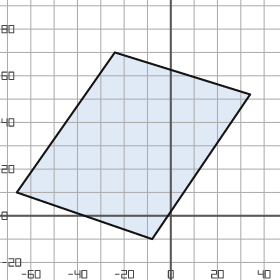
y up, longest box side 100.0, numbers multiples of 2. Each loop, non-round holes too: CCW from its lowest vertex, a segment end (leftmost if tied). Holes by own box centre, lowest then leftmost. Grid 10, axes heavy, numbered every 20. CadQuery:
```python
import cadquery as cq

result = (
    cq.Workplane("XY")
    .moveTo(-8.0, -10.0)
    .lineTo(34.0, 52.0)
    .lineTo(-24.0, 70.0)
    .lineTo(-66.0, 10.0)
    .close()
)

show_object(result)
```